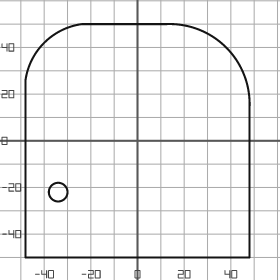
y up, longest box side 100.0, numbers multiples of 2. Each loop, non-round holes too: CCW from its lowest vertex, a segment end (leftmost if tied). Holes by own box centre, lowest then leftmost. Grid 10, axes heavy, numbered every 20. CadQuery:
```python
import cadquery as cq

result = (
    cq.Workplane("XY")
    .moveTo(-48.0, -50.0)
    .lineTo(48.0, -50.0)
    .lineTo(48.0, 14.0)
    .threePointArc((38.0, 40.0), (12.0, 50.0))
    .lineTo(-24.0, 50.0)
    .threePointArc((-40.0, 42.0), (-48.0, 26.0))
    .close()
    .moveTo(-34.0, -22.0)
    .circle(4.0)
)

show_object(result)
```